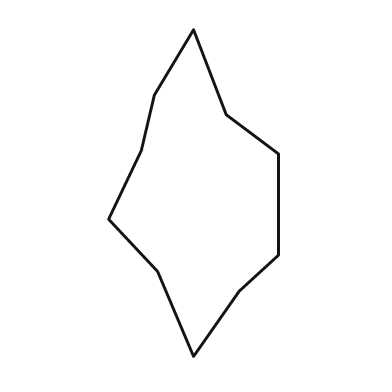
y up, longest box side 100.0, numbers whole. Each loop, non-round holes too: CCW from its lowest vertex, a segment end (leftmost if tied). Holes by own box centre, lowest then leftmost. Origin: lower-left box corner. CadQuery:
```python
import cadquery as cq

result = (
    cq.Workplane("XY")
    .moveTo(26.0, 0.0)
    .lineTo(40.0, 20.0)
    .lineTo(52.0, 31.0)
    .lineTo(52.0, 62.0)
    .lineTo(36.0, 74.0)
    .lineTo(26.0, 100.0)
    .lineTo(14.0, 80.0)
    .lineTo(10.0, 63.0)
    .lineTo(0.0, 42.0)
    .lineTo(15.0, 26.0)
    .close()
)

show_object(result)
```